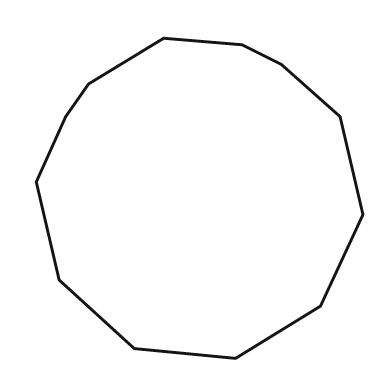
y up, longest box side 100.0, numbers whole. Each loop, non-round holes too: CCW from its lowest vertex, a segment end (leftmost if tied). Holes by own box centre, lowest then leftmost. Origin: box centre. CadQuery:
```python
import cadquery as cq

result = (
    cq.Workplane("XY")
    .moveTo(11.0, -49.0)
    .lineTo(37.0, -33.0)
    .lineTo(50.0, -5.0)
    .lineTo(43.0, 25.0)
    .lineTo(25.0, 41.0)
    .lineTo(13.0, 47.0)
    .lineTo(-11.0, 49.0)
    .lineTo(-34.0, 35.0)
    .lineTo(-41.0, 25.0)
    .lineTo(-50.0, 5.0)
    .lineTo(-43.0, -25.0)
    .lineTo(-20.0, -46.0)
    .close()
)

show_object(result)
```